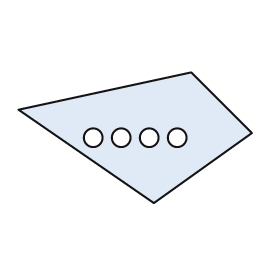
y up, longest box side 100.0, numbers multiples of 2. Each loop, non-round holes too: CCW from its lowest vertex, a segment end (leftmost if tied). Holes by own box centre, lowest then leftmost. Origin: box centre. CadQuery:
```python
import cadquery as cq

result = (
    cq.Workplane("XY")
    .moveTo(8.0, -28.0)
    .lineTo(50.0, 2.0)
    .lineTo(24.0, 28.0)
    .lineTo(-50.0, 12.0)
    .close()
    .moveTo(-18.0, 0.0)
    .circle(4.0)
    .moveTo(-6.0, 0.0)
    .circle(4.0)
    .moveTo(6.0, 0.0)
    .circle(4.0)
    .moveTo(18.0, 0.0)
    .circle(4.0)
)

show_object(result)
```